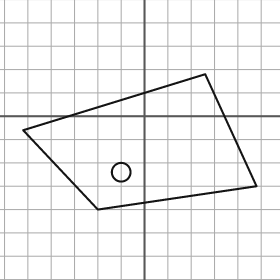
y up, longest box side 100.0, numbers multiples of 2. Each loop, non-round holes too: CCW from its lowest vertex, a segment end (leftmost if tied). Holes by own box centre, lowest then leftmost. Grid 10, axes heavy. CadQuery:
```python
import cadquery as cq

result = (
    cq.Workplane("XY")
    .moveTo(-20.0, -40.0)
    .lineTo(48.0, -30.0)
    .lineTo(26.0, 18.0)
    .lineTo(-52.0, -6.0)
    .close()
    .moveTo(-10.0, -24.0)
    .circle(4.0)
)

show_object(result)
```